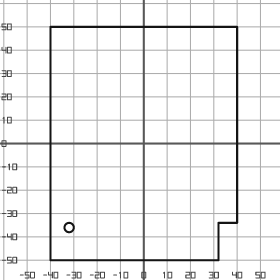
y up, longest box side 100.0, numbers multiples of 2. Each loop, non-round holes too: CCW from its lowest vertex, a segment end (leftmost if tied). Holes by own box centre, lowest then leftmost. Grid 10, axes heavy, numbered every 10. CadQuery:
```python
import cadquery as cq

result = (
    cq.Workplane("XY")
    .moveTo(-40.0, -50.0)
    .lineTo(32.0, -50.0)
    .lineTo(32.0, -34.0)
    .lineTo(40.0, -34.0)
    .lineTo(40.0, 50.0)
    .lineTo(-40.0, 50.0)
    .close()
    .moveTo(-32.0, -36.0)
    .circle(2.0)
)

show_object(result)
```